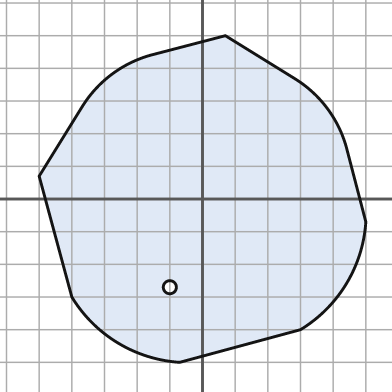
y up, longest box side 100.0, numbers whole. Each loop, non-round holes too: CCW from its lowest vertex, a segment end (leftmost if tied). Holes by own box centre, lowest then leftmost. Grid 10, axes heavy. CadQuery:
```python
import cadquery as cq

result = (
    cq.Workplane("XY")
    .moveTo(-7.0, -50.0)
    .lineTo(30.0, -40.0)
    .threePointArc((44.0, -26.0), (50.0, -7.0))
    .lineTo(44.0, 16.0)
    .threePointArc((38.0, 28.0), (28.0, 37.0))
    .lineTo(7.0, 50.0)
    .lineTo(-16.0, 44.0)
    .threePointArc((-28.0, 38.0), (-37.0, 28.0))
    .lineTo(-50.0, 7.0)
    .lineTo(-40.0, -30.0)
    .threePointArc((-26.0, -44.0), (-7.0, -50.0))
    .close()
    .moveTo(-10.0, -27.0)
    .circle(2.0)
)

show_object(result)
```